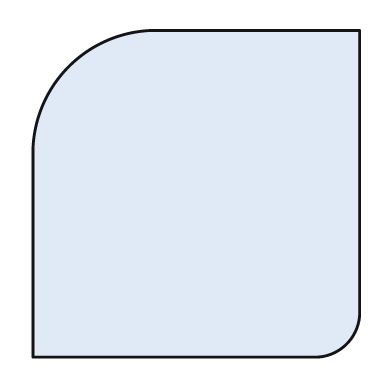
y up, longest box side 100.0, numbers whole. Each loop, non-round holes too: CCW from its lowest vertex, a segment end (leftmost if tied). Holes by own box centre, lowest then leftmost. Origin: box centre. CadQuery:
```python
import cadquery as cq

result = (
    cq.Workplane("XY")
    .moveTo(-50.0, -50.0)
    .lineTo(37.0, -50.0)
    .threePointArc((46.0, -46.0), (50.0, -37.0))
    .lineTo(50.0, 50.0)
    .lineTo(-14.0, 50.0)
    .threePointArc((-39.0, 39.0), (-50.0, 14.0))
    .close()
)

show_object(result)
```